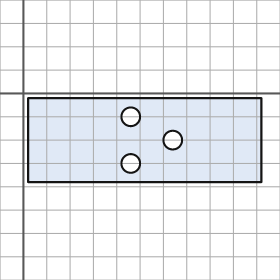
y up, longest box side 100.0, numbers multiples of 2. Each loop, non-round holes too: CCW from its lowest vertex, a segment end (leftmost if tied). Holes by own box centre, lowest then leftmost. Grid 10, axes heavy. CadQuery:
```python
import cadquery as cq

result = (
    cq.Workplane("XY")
    .moveTo(2.0, -38.0)
    .lineTo(102.0, -38.0)
    .lineTo(102.0, -2.0)
    .lineTo(2.0, -2.0)
    .close()
    .moveTo(46.0, -30.0)
    .circle(4.0)
    .moveTo(64.0, -20.0)
    .circle(4.0)
    .moveTo(46.0, -10.0)
    .circle(4.0)
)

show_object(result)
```